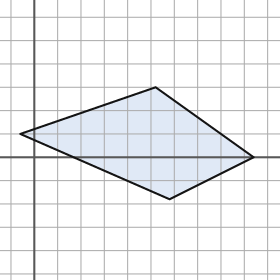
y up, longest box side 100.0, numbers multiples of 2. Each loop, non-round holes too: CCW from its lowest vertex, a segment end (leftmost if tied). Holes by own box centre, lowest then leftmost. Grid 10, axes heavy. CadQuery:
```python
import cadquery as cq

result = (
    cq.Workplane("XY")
    .moveTo(58.0, -18.0)
    .lineTo(94.0, 0.0)
    .lineTo(52.0, 30.0)
    .lineTo(-6.0, 10.0)
    .close()
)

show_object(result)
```